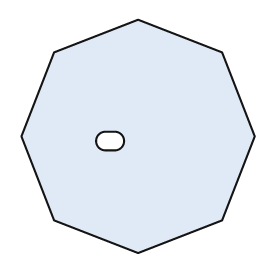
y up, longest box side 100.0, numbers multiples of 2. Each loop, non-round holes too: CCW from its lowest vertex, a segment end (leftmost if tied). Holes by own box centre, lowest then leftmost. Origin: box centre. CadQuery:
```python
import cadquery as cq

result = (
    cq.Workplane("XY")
    .moveTo(0.0, -50.0)
    .lineTo(36.0, -36.0)
    .lineTo(50.0, 0.0)
    .lineTo(36.0, 36.0)
    .lineTo(0.0, 50.0)
    .lineTo(-36.0, 36.0)
    .lineTo(-50.0, 0.0)
    .lineTo(-36.0, -36.0)
    .close()
    .moveTo(-14.0, -6.0)
    .lineTo(-10.0, -6.0)
    .threePointArc((-6.0, -2.0), (-10.0, 2.0))
    .lineTo(-14.0, 2.0)
    .threePointArc((-18.0, -2.0), (-14.0, -6.0))
    .close()
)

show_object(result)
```